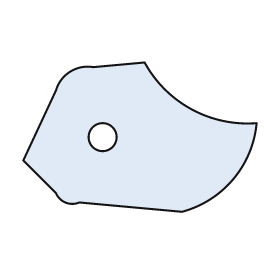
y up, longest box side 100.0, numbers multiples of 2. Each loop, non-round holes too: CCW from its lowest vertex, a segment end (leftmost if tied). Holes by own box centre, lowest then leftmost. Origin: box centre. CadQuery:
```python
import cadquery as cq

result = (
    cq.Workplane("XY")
    .moveTo(18.0, -32.0)
    .threePointArc((40.0, -18.0), (50.0, 6.0))
    .threePointArc((22.0, 12.0), (2.0, 32.0))
    .lineTo(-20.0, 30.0)
    .threePointArc((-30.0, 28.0), (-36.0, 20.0))
    .lineTo(-50.0, -10.0)
    .lineTo(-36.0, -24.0)
    .threePointArc((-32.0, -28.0), (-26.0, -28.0))
    .close()
    .moveTo(-16.0, 0.0)
    .circle(6.0)
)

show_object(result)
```